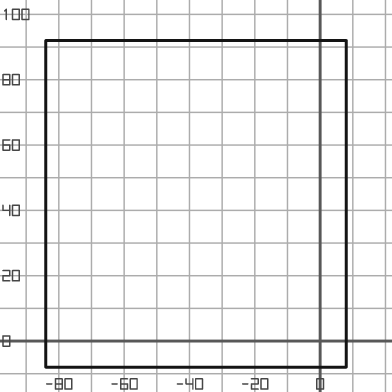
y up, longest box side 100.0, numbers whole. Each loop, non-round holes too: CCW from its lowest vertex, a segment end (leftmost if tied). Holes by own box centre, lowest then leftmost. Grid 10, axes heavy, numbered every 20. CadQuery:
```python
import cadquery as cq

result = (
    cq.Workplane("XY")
    .moveTo(-84.0, -8.0)
    .lineTo(8.0, -8.0)
    .lineTo(8.0, 92.0)
    .lineTo(-84.0, 92.0)
    .close()
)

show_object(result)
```